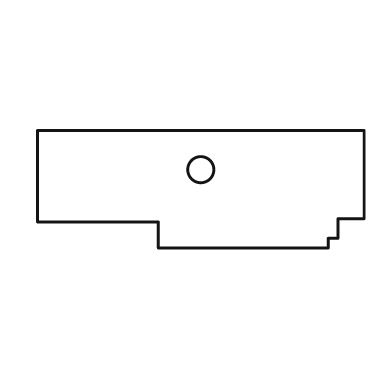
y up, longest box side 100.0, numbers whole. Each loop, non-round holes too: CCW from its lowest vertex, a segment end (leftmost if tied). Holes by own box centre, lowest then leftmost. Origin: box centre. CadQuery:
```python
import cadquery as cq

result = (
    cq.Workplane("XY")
    .moveTo(-13.0, -18.0)
    .lineTo(39.0, -18.0)
    .lineTo(39.0, -15.0)
    .lineTo(42.0, -15.0)
    .lineTo(42.0, -9.0)
    .lineTo(50.0, -9.0)
    .lineTo(50.0, 18.0)
    .lineTo(-50.0, 18.0)
    .lineTo(-50.0, -10.0)
    .lineTo(-13.0, -10.0)
    .close()
    .moveTo(0.0, 6.0)
    .circle(4.0)
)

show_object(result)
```